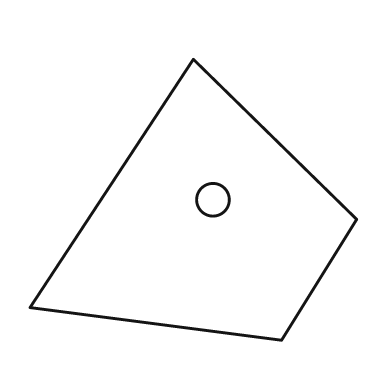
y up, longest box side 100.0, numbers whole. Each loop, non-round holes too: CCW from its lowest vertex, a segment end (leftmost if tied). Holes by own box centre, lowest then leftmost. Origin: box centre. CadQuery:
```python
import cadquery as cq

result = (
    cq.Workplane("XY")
    .moveTo(27.0, -43.0)
    .lineTo(50.0, -6.0)
    .lineTo(0.0, 43.0)
    .lineTo(-50.0, -33.0)
    .close()
    .moveTo(6.0, 0.0)
    .circle(5.0)
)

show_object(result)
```